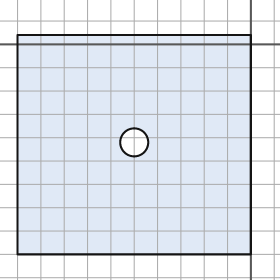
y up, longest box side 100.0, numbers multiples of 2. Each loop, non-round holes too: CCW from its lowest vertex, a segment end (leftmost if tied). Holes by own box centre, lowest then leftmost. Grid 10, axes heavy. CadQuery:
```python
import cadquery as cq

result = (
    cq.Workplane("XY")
    .moveTo(-100.0, -90.0)
    .lineTo(0.0, -90.0)
    .lineTo(0.0, 4.0)
    .lineTo(-100.0, 4.0)
    .close()
    .moveTo(-50.0, -42.0)
    .circle(6.0)
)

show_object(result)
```